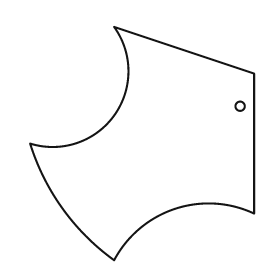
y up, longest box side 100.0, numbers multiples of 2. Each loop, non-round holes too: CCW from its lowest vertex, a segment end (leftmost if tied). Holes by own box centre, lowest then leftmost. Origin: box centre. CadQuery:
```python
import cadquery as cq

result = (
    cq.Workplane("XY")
    .moveTo(-12.0, -50.0)
    .threePointArc((14.0, -28.0), (48.0, -30.0))
    .lineTo(48.0, 30.0)
    .lineTo(-12.0, 50.0)
    .threePointArc((-12.0, 12.0), (-48.0, 0.0))
    .threePointArc((-34.0, -28.0), (-12.0, -50.0))
    .close()
    .moveTo(42.0, 16.0)
    .circle(2.0)
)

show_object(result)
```